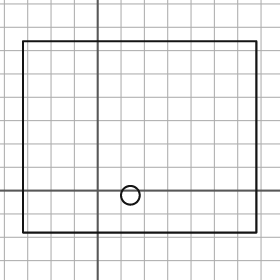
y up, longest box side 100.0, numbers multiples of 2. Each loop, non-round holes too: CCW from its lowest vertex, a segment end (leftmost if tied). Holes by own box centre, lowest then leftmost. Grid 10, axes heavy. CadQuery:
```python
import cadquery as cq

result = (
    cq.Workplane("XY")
    .moveTo(-32.0, -18.0)
    .lineTo(68.0, -18.0)
    .lineTo(68.0, 64.0)
    .lineTo(-32.0, 64.0)
    .close()
    .moveTo(14.0, -2.0)
    .circle(4.0)
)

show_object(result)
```